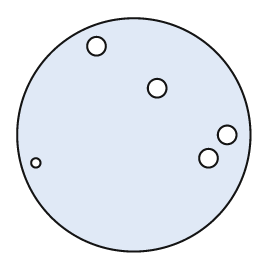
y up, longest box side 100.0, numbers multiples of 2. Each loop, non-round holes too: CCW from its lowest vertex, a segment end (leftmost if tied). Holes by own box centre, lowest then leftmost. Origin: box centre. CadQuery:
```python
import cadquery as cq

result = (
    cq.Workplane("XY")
    .moveTo(0.0, 0.0)
    .circle(50.0)
    .moveTo(-42.0, -12.0)
    .circle(2.0)
    .moveTo(32.0, -10.0)
    .circle(4.0)
    .moveTo(40.0, 0.0)
    .circle(4.0)
    .moveTo(10.0, 20.0)
    .circle(4.0)
    .moveTo(-16.0, 38.0)
    .circle(4.0)
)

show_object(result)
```